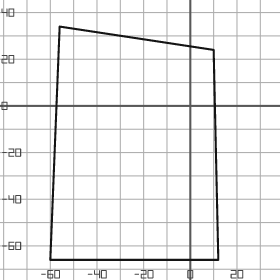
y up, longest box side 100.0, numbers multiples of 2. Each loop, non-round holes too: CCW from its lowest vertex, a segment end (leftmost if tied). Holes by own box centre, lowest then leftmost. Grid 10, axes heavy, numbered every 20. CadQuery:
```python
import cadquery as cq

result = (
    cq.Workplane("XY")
    .moveTo(-60.0, -66.0)
    .lineTo(12.0, -66.0)
    .lineTo(10.0, 24.0)
    .lineTo(-56.0, 34.0)
    .close()
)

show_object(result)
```